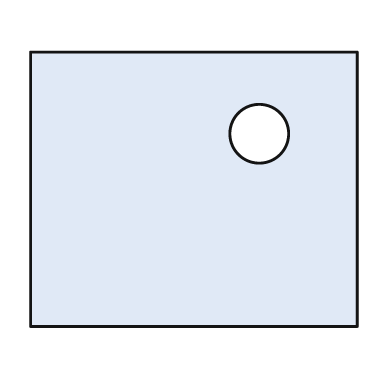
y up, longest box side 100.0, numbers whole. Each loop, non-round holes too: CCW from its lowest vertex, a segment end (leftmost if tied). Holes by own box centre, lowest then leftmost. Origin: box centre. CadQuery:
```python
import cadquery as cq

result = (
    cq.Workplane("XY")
    .moveTo(-50.0, -42.0)
    .lineTo(50.0, -42.0)
    .lineTo(50.0, 42.0)
    .lineTo(-50.0, 42.0)
    .close()
    .moveTo(20.0, 17.0)
    .circle(9.0)
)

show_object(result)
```